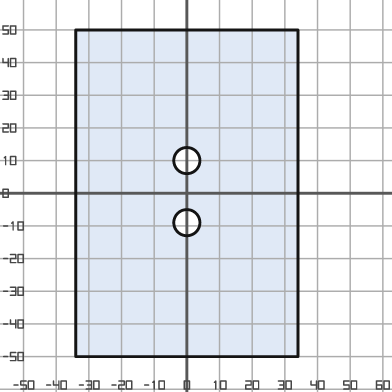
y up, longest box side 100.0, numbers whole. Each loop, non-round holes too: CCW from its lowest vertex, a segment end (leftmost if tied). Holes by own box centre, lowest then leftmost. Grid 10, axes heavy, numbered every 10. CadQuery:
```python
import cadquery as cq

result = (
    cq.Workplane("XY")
    .moveTo(-34.0, -50.0)
    .lineTo(34.0, -50.0)
    .lineTo(34.0, 50.0)
    .lineTo(-34.0, 50.0)
    .close()
    .moveTo(0.0, -9.0)
    .circle(4.0)
    .moveTo(0.0, 10.0)
    .circle(4.0)
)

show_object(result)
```